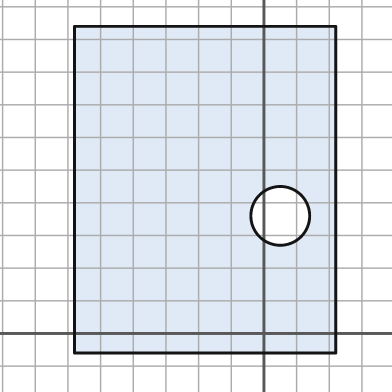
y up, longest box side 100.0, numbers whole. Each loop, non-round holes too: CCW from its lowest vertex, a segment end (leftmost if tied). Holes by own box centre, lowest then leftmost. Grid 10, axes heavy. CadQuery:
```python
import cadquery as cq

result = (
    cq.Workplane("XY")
    .moveTo(-58.0, -6.0)
    .lineTo(22.0, -6.0)
    .lineTo(22.0, 94.0)
    .lineTo(-58.0, 94.0)
    .close()
    .moveTo(5.0, 36.0)
    .circle(9.0)
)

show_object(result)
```